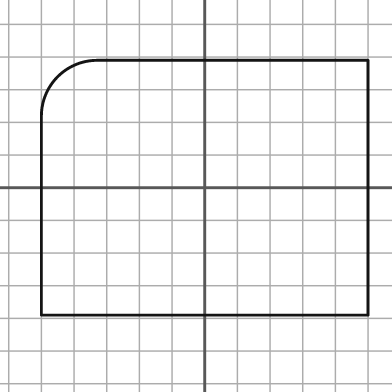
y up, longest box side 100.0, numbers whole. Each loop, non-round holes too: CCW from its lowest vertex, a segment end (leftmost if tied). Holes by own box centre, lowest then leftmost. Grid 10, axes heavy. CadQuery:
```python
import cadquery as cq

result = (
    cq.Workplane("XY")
    .moveTo(-50.0, -39.0)
    .lineTo(50.0, -39.0)
    .lineTo(50.0, 39.0)
    .lineTo(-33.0, 39.0)
    .threePointArc((-45.0, 34.0), (-50.0, 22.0))
    .close()
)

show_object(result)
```